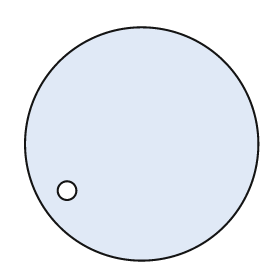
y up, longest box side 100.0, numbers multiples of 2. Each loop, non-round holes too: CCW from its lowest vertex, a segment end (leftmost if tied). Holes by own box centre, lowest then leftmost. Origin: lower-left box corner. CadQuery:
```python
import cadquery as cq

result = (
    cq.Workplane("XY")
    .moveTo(50.0, 50.0)
    .circle(50.0)
    .moveTo(18.0, 30.0)
    .circle(4.0)
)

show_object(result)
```